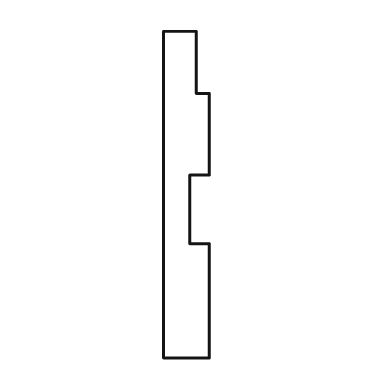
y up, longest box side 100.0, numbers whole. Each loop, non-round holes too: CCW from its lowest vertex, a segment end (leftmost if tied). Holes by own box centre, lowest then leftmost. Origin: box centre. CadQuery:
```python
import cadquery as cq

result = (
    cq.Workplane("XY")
    .moveTo(-7.0, -50.0)
    .lineTo(7.0, -50.0)
    .lineTo(7.0, -15.0)
    .lineTo(1.0, -15.0)
    .lineTo(1.0, 6.0)
    .lineTo(7.0, 6.0)
    .lineTo(7.0, 31.0)
    .lineTo(3.0, 31.0)
    .lineTo(3.0, 50.0)
    .lineTo(-7.0, 50.0)
    .close()
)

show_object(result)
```